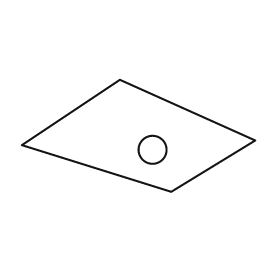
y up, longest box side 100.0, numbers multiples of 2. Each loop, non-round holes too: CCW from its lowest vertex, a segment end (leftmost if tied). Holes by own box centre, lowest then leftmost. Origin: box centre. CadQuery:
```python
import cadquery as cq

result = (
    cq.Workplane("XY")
    .moveTo(14.0, -24.0)
    .lineTo(50.0, -2.0)
    .lineTo(-8.0, 24.0)
    .lineTo(-50.0, -4.0)
    .close()
    .moveTo(6.0, -6.0)
    .circle(6.0)
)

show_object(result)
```